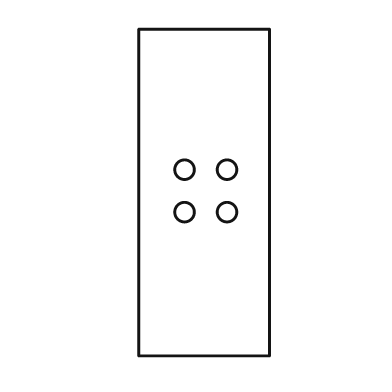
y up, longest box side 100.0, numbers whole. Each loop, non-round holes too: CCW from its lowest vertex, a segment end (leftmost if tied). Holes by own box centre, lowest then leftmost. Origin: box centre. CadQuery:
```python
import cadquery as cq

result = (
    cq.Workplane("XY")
    .moveTo(-20.0, -50.0)
    .lineTo(20.0, -50.0)
    .lineTo(20.0, 50.0)
    .lineTo(-20.0, 50.0)
    .close()
    .moveTo(-6.0, -6.0)
    .circle(3.0)
    .moveTo(7.0, -6.0)
    .circle(3.0)
    .moveTo(-6.0, 7.0)
    .circle(3.0)
    .moveTo(7.0, 7.0)
    .circle(3.0)
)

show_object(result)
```